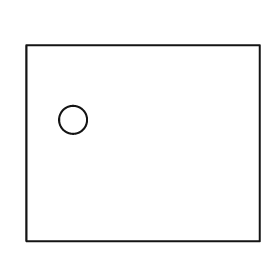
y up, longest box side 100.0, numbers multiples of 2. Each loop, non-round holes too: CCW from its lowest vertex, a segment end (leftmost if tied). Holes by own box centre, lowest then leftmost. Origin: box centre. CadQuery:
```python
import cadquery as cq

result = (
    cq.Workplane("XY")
    .moveTo(-50.0, -42.0)
    .lineTo(50.0, -42.0)
    .lineTo(50.0, 42.0)
    .lineTo(-50.0, 42.0)
    .close()
    .moveTo(-30.0, 10.0)
    .circle(6.0)
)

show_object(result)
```